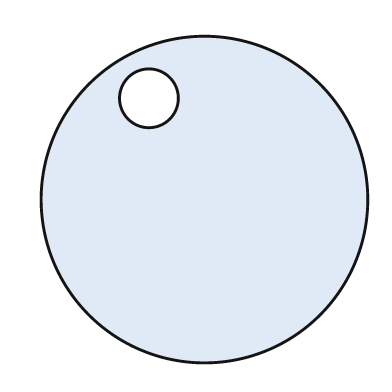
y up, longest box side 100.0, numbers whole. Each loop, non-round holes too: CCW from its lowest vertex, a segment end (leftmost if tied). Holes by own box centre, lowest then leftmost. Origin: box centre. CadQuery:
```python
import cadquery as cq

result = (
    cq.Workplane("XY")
    .moveTo(0.0, 0.0)
    .circle(50.0)
    .moveTo(-17.0, 31.0)
    .circle(9.0)
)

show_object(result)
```